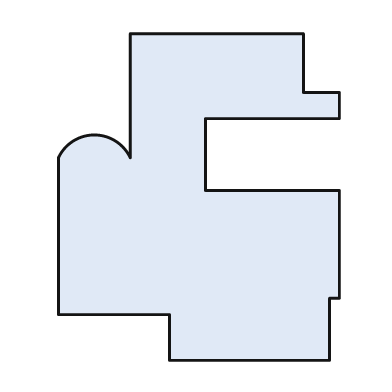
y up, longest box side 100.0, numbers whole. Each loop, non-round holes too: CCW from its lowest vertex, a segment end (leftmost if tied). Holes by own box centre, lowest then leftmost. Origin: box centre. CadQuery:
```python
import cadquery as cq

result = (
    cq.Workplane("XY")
    .moveTo(-9.0, -50.0)
    .lineTo(40.0, -50.0)
    .lineTo(40.0, -31.0)
    .lineTo(43.0, -31.0)
    .lineTo(43.0, 2.0)
    .lineTo(2.0, 2.0)
    .lineTo(2.0, 24.0)
    .lineTo(43.0, 24.0)
    .lineTo(43.0, 32.0)
    .lineTo(32.0, 32.0)
    .lineTo(32.0, 50.0)
    .lineTo(-21.0, 50.0)
    .lineTo(-21.0, 12.0)
    .threePointArc((-32.0, 19.0), (-43.0, 12.0))
    .lineTo(-43.0, -36.0)
    .lineTo(-9.0, -36.0)
    .close()
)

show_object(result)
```